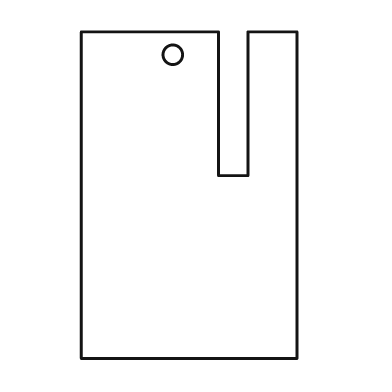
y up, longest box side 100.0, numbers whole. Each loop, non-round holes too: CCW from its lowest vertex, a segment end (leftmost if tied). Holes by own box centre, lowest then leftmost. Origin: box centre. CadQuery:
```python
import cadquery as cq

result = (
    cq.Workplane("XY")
    .moveTo(-33.0, -50.0)
    .lineTo(33.0, -50.0)
    .lineTo(33.0, 50.0)
    .lineTo(18.0, 50.0)
    .lineTo(18.0, 6.0)
    .lineTo(9.0, 6.0)
    .lineTo(9.0, 50.0)
    .lineTo(-33.0, 50.0)
    .close()
    .moveTo(-5.0, 43.0)
    .circle(3.0)
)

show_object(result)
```